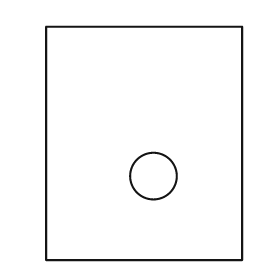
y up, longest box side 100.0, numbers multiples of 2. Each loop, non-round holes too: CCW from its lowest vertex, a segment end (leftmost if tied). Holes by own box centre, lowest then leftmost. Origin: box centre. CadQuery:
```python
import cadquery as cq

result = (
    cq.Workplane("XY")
    .moveTo(-42.0, -50.0)
    .lineTo(42.0, -50.0)
    .lineTo(42.0, 50.0)
    .lineTo(-42.0, 50.0)
    .close()
    .moveTo(4.0, -14.0)
    .circle(10.0)
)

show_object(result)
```